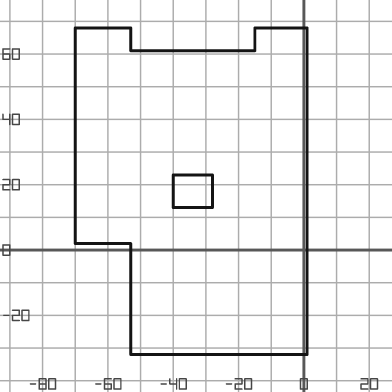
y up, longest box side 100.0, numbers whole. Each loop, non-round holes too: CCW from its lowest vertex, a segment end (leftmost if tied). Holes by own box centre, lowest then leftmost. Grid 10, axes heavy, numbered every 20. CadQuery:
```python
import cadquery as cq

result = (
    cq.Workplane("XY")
    .moveTo(-53.0, -32.0)
    .lineTo(1.0, -32.0)
    .lineTo(1.0, 68.0)
    .lineTo(-15.0, 68.0)
    .lineTo(-15.0, 61.0)
    .lineTo(-53.0, 61.0)
    .lineTo(-53.0, 68.0)
    .lineTo(-70.0, 68.0)
    .lineTo(-70.0, 2.0)
    .lineTo(-53.0, 2.0)
    .close()
    .moveTo(-40.0, 13.0)
    .lineTo(-28.0, 13.0)
    .lineTo(-28.0, 23.0)
    .lineTo(-40.0, 23.0)
    .close()
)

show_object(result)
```